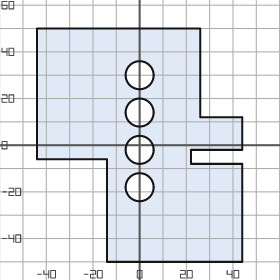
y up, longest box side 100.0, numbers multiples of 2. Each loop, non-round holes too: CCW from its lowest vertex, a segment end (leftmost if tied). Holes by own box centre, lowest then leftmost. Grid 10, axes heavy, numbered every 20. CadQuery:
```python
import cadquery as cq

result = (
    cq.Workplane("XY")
    .moveTo(-14.0, -50.0)
    .lineTo(44.0, -50.0)
    .lineTo(44.0, -8.0)
    .lineTo(22.0, -8.0)
    .lineTo(22.0, -2.0)
    .lineTo(44.0, -2.0)
    .lineTo(44.0, 12.0)
    .lineTo(26.0, 12.0)
    .lineTo(26.0, 50.0)
    .lineTo(-44.0, 50.0)
    .lineTo(-44.0, -6.0)
    .lineTo(-14.0, -6.0)
    .close()
    .moveTo(0.0, -18.0)
    .circle(6.0)
    .moveTo(0.0, -2.0)
    .circle(6.0)
    .moveTo(0.0, 14.0)
    .circle(6.0)
    .moveTo(0.0, 30.0)
    .circle(6.0)
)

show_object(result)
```